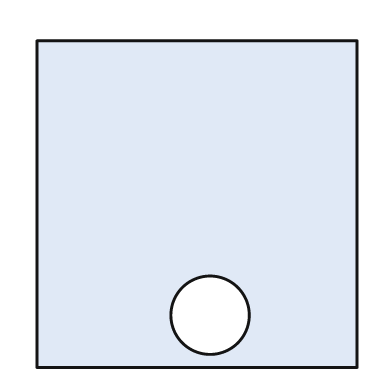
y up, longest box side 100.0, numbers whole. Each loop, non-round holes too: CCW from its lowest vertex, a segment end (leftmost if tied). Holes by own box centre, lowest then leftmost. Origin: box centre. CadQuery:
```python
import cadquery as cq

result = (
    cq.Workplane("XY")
    .moveTo(-49.0, -50.0)
    .lineTo(49.0, -50.0)
    .lineTo(49.0, 50.0)
    .lineTo(-49.0, 50.0)
    .close()
    .moveTo(4.0, -34.0)
    .circle(12.0)
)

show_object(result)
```